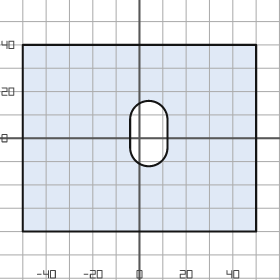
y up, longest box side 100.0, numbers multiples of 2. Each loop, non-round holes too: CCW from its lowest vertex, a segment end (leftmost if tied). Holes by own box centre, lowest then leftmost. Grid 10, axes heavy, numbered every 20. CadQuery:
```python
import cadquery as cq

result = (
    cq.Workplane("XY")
    .moveTo(-50.0, -40.0)
    .lineTo(50.0, -40.0)
    .lineTo(50.0, 40.0)
    .lineTo(-50.0, 40.0)
    .close()
    .moveTo(-4.0, -4.0)
    .threePointArc((4.0, -12.0), (12.0, -4.0))
    .lineTo(12.0, 8.0)
    .threePointArc((4.0, 16.0), (-4.0, 8.0))
    .close()
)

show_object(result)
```